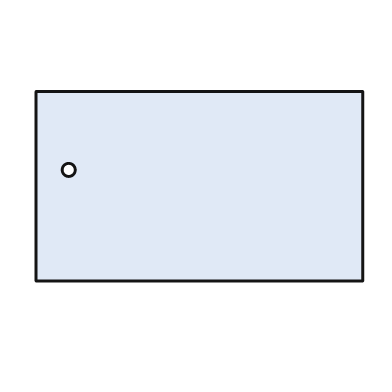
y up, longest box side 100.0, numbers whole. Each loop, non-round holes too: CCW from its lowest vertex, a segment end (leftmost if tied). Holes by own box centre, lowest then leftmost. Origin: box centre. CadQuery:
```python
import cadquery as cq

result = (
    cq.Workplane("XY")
    .moveTo(-50.0, -29.0)
    .lineTo(50.0, -29.0)
    .lineTo(50.0, 29.0)
    .lineTo(-50.0, 29.0)
    .close()
    .moveTo(-40.0, 5.0)
    .circle(2.0)
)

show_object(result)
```